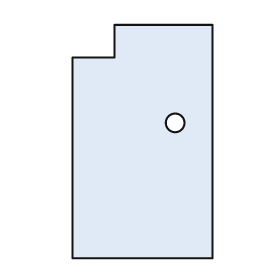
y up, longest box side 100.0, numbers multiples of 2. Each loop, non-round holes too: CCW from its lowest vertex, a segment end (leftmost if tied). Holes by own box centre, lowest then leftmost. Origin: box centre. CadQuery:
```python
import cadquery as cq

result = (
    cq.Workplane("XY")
    .moveTo(-30.0, -50.0)
    .lineTo(30.0, -50.0)
    .lineTo(30.0, 50.0)
    .lineTo(-12.0, 50.0)
    .lineTo(-12.0, 36.0)
    .lineTo(-30.0, 36.0)
    .close()
    .moveTo(14.0, 8.0)
    .circle(4.0)
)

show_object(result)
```